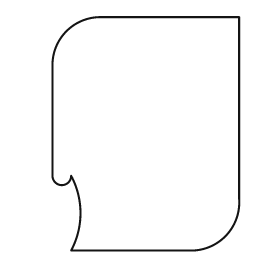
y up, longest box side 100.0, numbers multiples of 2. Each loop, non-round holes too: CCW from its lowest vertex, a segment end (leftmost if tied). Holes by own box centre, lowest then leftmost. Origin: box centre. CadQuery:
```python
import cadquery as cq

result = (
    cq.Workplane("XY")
    .moveTo(-32.0, -50.0)
    .lineTo(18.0, -50.0)
    .threePointArc((34.0, -44.0), (40.0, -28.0))
    .lineTo(40.0, 50.0)
    .lineTo(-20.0, 50.0)
    .threePointArc((-34.0, 44.0), (-40.0, 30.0))
    .lineTo(-40.0, -18.0)
    .threePointArc((-36.0, -22.0), (-32.0, -18.0))
    .threePointArc((-28.0, -34.0), (-32.0, -50.0))
    .close()
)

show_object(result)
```